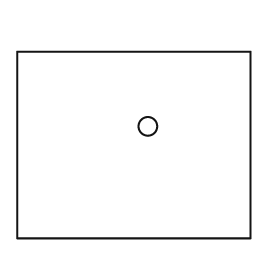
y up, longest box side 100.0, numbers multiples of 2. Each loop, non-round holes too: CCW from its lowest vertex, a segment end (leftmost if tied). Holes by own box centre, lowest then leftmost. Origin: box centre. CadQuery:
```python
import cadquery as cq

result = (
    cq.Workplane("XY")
    .moveTo(-50.0, -40.0)
    .lineTo(50.0, -40.0)
    .lineTo(50.0, 40.0)
    .lineTo(-50.0, 40.0)
    .close()
    .moveTo(6.0, 8.0)
    .circle(4.0)
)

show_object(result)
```